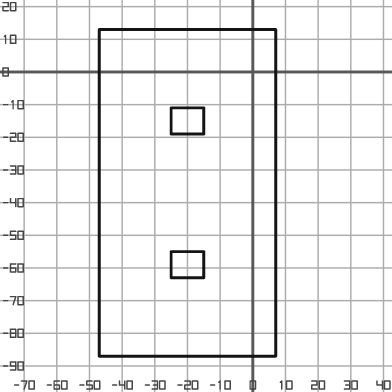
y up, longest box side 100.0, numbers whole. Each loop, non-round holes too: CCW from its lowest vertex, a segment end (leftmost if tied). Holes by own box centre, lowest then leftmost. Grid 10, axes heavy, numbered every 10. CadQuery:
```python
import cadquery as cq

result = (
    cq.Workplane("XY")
    .moveTo(-47.0, -87.0)
    .lineTo(7.0, -87.0)
    .lineTo(7.0, 13.0)
    .lineTo(-47.0, 13.0)
    .close()
    .moveTo(-25.0, -63.0)
    .lineTo(-15.0, -63.0)
    .lineTo(-15.0, -55.0)
    .lineTo(-25.0, -55.0)
    .close()
    .moveTo(-25.0, -19.0)
    .lineTo(-15.0, -19.0)
    .lineTo(-15.0, -11.0)
    .lineTo(-25.0, -11.0)
    .close()
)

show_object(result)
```